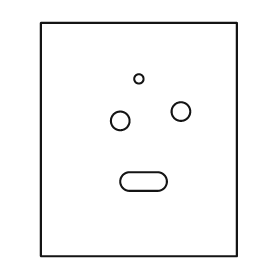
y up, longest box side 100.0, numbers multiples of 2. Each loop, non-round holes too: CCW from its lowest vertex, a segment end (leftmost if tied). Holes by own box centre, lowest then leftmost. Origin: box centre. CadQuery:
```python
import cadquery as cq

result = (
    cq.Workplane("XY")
    .moveTo(-42.0, -50.0)
    .lineTo(42.0, -50.0)
    .lineTo(42.0, 50.0)
    .lineTo(-42.0, 50.0)
    .close()
    .moveTo(-4.0, -22.0)
    .lineTo(8.0, -22.0)
    .threePointArc((12.0, -18.0), (8.0, -14.0))
    .lineTo(-4.0, -14.0)
    .threePointArc((-8.0, -18.0), (-4.0, -22.0))
    .close()
    .moveTo(-8.0, 8.0)
    .circle(4.0)
    .moveTo(18.0, 12.0)
    .circle(4.0)
    .moveTo(0.0, 26.0)
    .circle(2.0)
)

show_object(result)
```